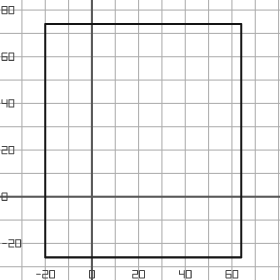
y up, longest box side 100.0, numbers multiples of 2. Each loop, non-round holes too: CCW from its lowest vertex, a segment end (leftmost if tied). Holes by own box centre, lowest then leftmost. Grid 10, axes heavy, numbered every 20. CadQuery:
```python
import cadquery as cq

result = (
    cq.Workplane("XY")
    .moveTo(-20.0, -26.0)
    .lineTo(64.0, -26.0)
    .lineTo(64.0, 74.0)
    .lineTo(-20.0, 74.0)
    .close()
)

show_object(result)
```